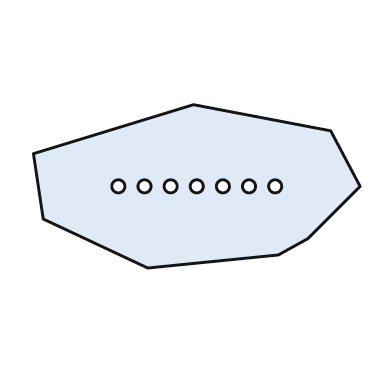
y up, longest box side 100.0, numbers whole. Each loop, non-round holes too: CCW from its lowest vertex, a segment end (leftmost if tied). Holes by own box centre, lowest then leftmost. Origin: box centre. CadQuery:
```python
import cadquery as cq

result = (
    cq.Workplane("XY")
    .moveTo(-15.0, -25.0)
    .lineTo(25.0, -21.0)
    .lineTo(34.0, -16.0)
    .lineTo(50.0, 0.0)
    .lineTo(41.0, 17.0)
    .lineTo(-1.0, 25.0)
    .lineTo(-50.0, 10.0)
    .lineTo(-47.0, -10.0)
    .close()
    .moveTo(-24.0, 0.0)
    .circle(2.0)
    .moveTo(-16.0, 0.0)
    .circle(2.0)
    .moveTo(-8.0, 0.0)
    .circle(2.0)
    .moveTo(0.0, 0.0)
    .circle(2.0)
    .moveTo(8.0, 0.0)
    .circle(2.0)
    .moveTo(16.0, 0.0)
    .circle(2.0)
    .moveTo(24.0, 0.0)
    .circle(2.0)
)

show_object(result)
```